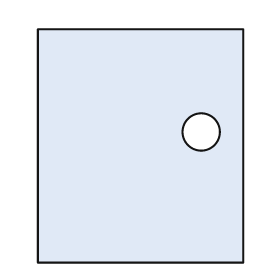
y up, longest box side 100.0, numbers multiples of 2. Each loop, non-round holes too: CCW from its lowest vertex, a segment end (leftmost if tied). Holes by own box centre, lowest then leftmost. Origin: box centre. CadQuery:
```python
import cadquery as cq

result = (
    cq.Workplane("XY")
    .moveTo(-44.0, -50.0)
    .lineTo(44.0, -50.0)
    .lineTo(44.0, 50.0)
    .lineTo(-44.0, 50.0)
    .close()
    .moveTo(26.0, 6.0)
    .circle(8.0)
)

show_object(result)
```